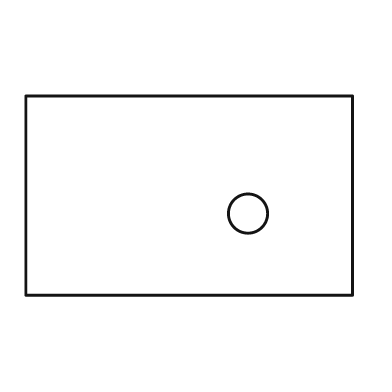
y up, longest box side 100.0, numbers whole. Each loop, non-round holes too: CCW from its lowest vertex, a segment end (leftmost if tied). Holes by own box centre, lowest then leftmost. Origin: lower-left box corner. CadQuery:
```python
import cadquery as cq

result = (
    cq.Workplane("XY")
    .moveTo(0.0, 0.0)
    .lineTo(100.0, 0.0)
    .lineTo(100.0, 61.0)
    .lineTo(0.0, 61.0)
    .close()
    .moveTo(68.0, 25.0)
    .circle(6.0)
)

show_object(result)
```